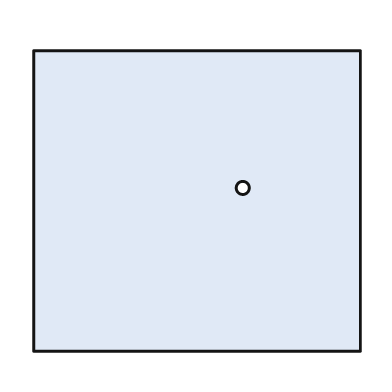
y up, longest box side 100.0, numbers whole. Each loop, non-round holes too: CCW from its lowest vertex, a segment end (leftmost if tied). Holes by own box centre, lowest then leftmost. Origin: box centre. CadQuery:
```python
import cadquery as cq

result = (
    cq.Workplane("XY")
    .moveTo(-50.0, -46.0)
    .lineTo(50.0, -46.0)
    .lineTo(50.0, 46.0)
    .lineTo(-50.0, 46.0)
    .close()
    .moveTo(14.0, 4.0)
    .circle(2.0)
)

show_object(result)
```